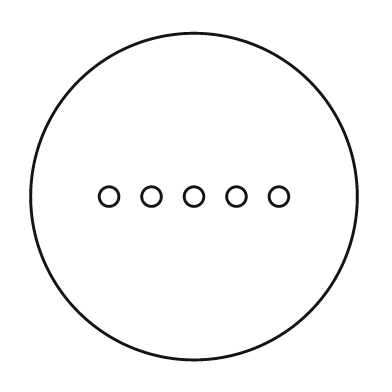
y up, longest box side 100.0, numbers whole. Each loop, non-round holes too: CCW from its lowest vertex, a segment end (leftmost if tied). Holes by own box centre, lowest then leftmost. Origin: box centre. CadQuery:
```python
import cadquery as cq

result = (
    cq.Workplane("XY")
    .moveTo(0.0, 0.0)
    .circle(50.0)
    .moveTo(-26.0, 0.0)
    .circle(3.0)
    .moveTo(-13.0, 0.0)
    .circle(3.0)
    .moveTo(0.0, 0.0)
    .circle(3.0)
    .moveTo(13.0, 0.0)
    .circle(3.0)
    .moveTo(26.0, 0.0)
    .circle(3.0)
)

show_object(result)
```